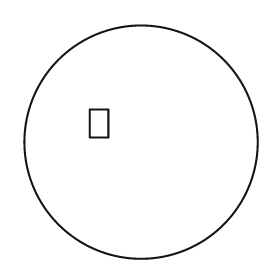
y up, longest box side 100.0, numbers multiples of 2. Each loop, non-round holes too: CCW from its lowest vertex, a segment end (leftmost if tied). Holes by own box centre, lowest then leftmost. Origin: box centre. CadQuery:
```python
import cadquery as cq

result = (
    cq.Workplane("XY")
    .moveTo(0.0, 0.0)
    .circle(50.0)
    .moveTo(-22.0, 2.0)
    .lineTo(-14.0, 2.0)
    .lineTo(-14.0, 14.0)
    .lineTo(-22.0, 14.0)
    .close()
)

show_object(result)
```